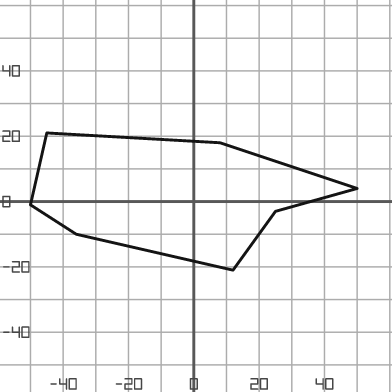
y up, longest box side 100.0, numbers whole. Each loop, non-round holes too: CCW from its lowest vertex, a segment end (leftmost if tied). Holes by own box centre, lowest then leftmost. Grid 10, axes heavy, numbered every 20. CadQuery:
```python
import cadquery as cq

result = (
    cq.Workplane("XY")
    .moveTo(12.0, -21.0)
    .lineTo(25.0, -3.0)
    .lineTo(50.0, 4.0)
    .lineTo(8.0, 18.0)
    .lineTo(-45.0, 21.0)
    .lineTo(-50.0, -1.0)
    .lineTo(-36.0, -10.0)
    .close()
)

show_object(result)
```